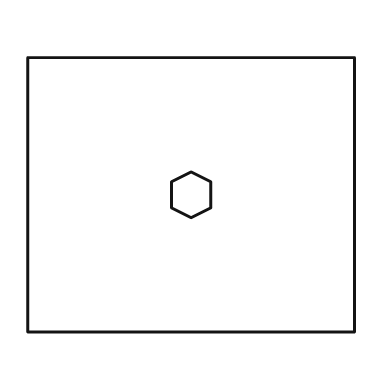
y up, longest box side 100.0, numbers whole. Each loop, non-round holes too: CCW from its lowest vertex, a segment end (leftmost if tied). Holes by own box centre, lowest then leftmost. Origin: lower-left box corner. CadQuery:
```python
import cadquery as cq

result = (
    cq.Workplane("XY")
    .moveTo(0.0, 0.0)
    .lineTo(100.0, 0.0)
    .lineTo(100.0, 84.0)
    .lineTo(0.0, 84.0)
    .close()
    .moveTo(50.0, 35.0)
    .lineTo(56.0, 38.0)
    .lineTo(56.0, 46.0)
    .lineTo(50.0, 49.0)
    .lineTo(44.0, 46.0)
    .lineTo(44.0, 38.0)
    .close()
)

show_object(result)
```